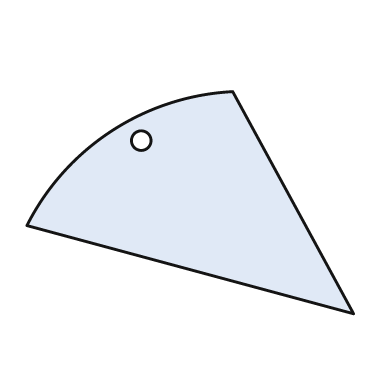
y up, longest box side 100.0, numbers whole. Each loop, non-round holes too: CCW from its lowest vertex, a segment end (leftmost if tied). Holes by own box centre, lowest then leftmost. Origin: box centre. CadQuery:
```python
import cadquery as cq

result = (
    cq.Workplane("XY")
    .moveTo(50.0, -34.0)
    .lineTo(13.0, 34.0)
    .threePointArc((-24.0, 22.0), (-50.0, -7.0))
    .close()
    .moveTo(-15.0, 19.0)
    .circle(3.0)
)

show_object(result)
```